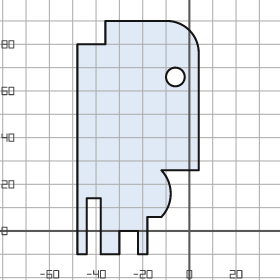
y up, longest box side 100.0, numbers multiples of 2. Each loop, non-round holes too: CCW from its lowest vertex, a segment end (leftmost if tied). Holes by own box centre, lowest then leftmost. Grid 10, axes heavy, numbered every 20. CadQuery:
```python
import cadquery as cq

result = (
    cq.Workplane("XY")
    .moveTo(-48.0, -10.0)
    .lineTo(-44.0, -10.0)
    .lineTo(-44.0, 14.0)
    .lineTo(-38.0, 14.0)
    .lineTo(-38.0, -10.0)
    .lineTo(-30.0, -10.0)
    .lineTo(-30.0, 0.0)
    .lineTo(-22.0, 0.0)
    .lineTo(-22.0, -10.0)
    .lineTo(-18.0, -10.0)
    .lineTo(-18.0, 6.0)
    .lineTo(-12.0, 6.0)
    .threePointArc((-8.0, 16.0), (-12.0, 26.0))
    .lineTo(4.0, 26.0)
    .lineTo(4.0, 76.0)
    .threePointArc((0.0, 86.0), (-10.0, 90.0))
    .lineTo(-36.0, 90.0)
    .lineTo(-36.0, 80.0)
    .lineTo(-48.0, 80.0)
    .close()
    .moveTo(-6.0, 66.0)
    .circle(4.0)
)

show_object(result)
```